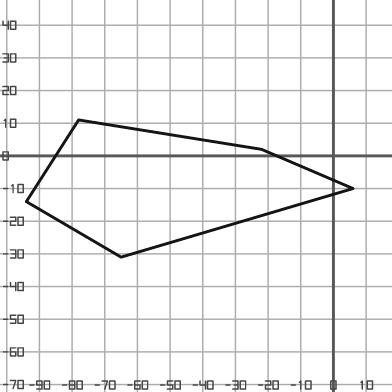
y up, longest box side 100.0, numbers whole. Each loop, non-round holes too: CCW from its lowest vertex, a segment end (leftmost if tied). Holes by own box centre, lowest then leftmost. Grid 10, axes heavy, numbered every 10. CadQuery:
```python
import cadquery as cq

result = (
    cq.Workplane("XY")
    .moveTo(-65.0, -31.0)
    .lineTo(6.0, -10.0)
    .lineTo(-22.0, 2.0)
    .lineTo(-78.0, 11.0)
    .lineTo(-94.0, -14.0)
    .close()
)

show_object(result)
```